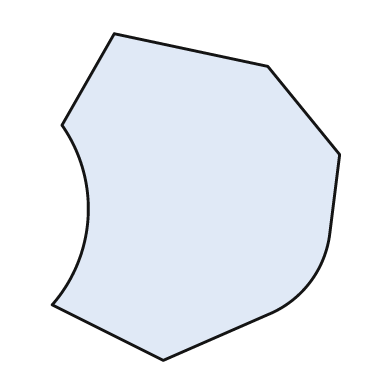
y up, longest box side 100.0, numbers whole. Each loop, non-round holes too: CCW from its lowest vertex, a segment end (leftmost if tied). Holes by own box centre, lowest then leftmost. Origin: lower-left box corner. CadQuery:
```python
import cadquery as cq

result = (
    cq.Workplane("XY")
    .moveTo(34.0, 0.0)
    .lineTo(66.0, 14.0)
    .threePointArc((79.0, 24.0), (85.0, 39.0))
    .lineTo(88.0, 63.0)
    .lineTo(66.0, 90.0)
    .lineTo(19.0, 100.0)
    .lineTo(3.0, 72.0)
    .threePointArc((11.0, 44.0), (0.0, 17.0))
    .close()
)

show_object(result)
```